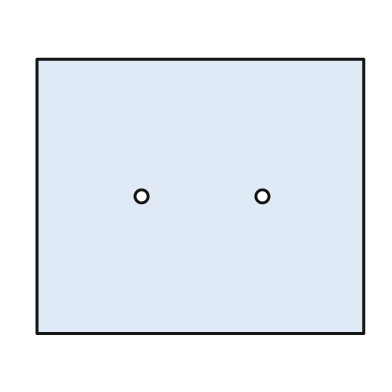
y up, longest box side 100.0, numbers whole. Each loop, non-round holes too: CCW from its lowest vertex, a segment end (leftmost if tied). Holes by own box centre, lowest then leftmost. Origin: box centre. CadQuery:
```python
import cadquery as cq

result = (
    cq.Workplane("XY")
    .moveTo(-50.0, -42.0)
    .lineTo(50.0, -42.0)
    .lineTo(50.0, 42.0)
    .lineTo(-50.0, 42.0)
    .close()
    .moveTo(-18.0, 0.0)
    .circle(2.0)
    .moveTo(19.0, 0.0)
    .circle(2.0)
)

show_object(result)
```